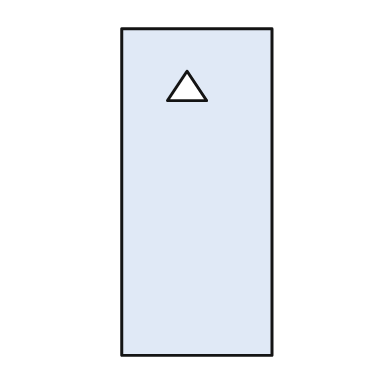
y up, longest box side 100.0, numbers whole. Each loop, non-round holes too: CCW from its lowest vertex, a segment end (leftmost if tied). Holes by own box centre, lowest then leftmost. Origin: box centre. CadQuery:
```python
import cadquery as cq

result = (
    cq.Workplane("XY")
    .moveTo(-23.0, -50.0)
    .lineTo(23.0, -50.0)
    .lineTo(23.0, 50.0)
    .lineTo(-23.0, 50.0)
    .close()
    .moveTo(-9.0, 28.0)
    .lineTo(3.0, 28.0)
    .lineTo(-3.0, 37.0)
    .close()
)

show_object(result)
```